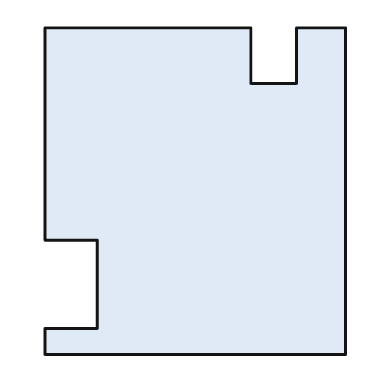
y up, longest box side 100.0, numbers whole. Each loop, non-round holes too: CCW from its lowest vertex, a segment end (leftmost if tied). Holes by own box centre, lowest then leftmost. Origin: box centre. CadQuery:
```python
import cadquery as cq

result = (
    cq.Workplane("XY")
    .moveTo(-46.0, -50.0)
    .lineTo(46.0, -50.0)
    .lineTo(46.0, 50.0)
    .lineTo(31.0, 50.0)
    .lineTo(31.0, 33.0)
    .lineTo(17.0, 33.0)
    .lineTo(17.0, 50.0)
    .lineTo(-46.0, 50.0)
    .lineTo(-46.0, -15.0)
    .lineTo(-30.0, -15.0)
    .lineTo(-30.0, -42.0)
    .lineTo(-46.0, -42.0)
    .close()
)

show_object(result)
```